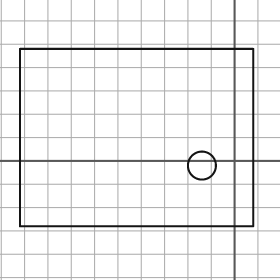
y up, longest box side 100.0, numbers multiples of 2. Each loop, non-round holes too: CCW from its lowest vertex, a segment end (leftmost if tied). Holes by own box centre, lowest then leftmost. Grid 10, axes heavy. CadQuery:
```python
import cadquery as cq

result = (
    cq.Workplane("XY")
    .moveTo(-92.0, -28.0)
    .lineTo(8.0, -28.0)
    .lineTo(8.0, 48.0)
    .lineTo(-92.0, 48.0)
    .close()
    .moveTo(-14.0, -2.0)
    .circle(6.0)
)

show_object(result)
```